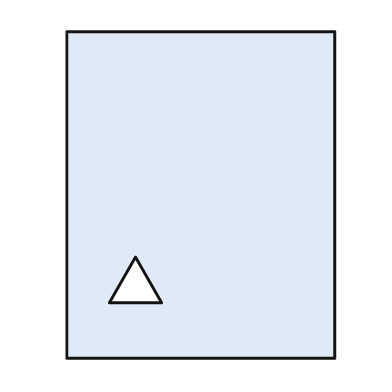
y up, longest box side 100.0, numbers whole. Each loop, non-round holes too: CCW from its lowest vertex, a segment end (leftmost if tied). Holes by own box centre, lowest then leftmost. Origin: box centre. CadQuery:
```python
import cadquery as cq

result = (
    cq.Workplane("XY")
    .moveTo(-41.0, -50.0)
    .lineTo(41.0, -50.0)
    .lineTo(41.0, 50.0)
    .lineTo(-41.0, 50.0)
    .close()
    .moveTo(-28.0, -33.0)
    .lineTo(-12.0, -33.0)
    .lineTo(-20.0, -19.0)
    .close()
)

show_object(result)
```